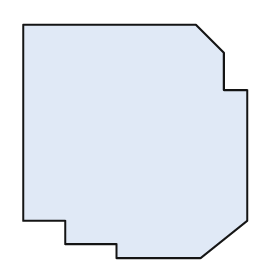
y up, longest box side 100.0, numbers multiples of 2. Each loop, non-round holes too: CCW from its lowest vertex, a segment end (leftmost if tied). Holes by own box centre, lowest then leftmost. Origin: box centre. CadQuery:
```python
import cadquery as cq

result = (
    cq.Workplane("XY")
    .moveTo(-8.0, -50.0)
    .lineTo(28.0, -50.0)
    .lineTo(48.0, -34.0)
    .lineTo(48.0, 22.0)
    .lineTo(38.0, 22.0)
    .lineTo(38.0, 38.0)
    .lineTo(26.0, 50.0)
    .lineTo(-48.0, 50.0)
    .lineTo(-48.0, -34.0)
    .lineTo(-30.0, -34.0)
    .lineTo(-30.0, -44.0)
    .lineTo(-8.0, -44.0)
    .close()
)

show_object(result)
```